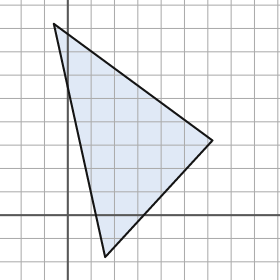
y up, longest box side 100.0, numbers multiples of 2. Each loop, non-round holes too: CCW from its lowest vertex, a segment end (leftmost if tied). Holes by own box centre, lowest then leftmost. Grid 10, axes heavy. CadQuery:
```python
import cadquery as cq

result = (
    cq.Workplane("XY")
    .moveTo(16.0, -18.0)
    .lineTo(62.0, 32.0)
    .lineTo(-6.0, 82.0)
    .close()
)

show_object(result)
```